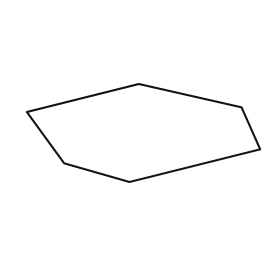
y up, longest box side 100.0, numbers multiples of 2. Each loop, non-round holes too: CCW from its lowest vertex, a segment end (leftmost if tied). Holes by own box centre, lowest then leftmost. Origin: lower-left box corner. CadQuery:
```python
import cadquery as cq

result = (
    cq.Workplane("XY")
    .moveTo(44.0, 0.0)
    .lineTo(100.0, 14.0)
    .lineTo(92.0, 32.0)
    .lineTo(48.0, 42.0)
    .lineTo(0.0, 30.0)
    .lineTo(16.0, 8.0)
    .close()
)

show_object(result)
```